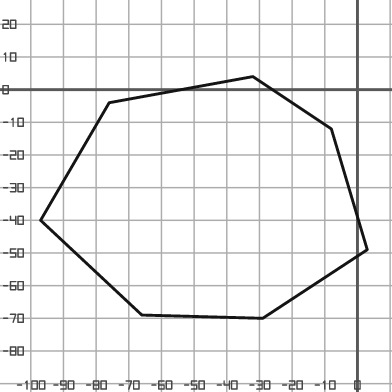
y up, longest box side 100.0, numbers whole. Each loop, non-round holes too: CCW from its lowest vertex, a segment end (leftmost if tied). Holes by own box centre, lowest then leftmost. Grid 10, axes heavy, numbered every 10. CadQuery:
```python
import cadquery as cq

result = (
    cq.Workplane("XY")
    .moveTo(-29.0, -70.0)
    .lineTo(3.0, -49.0)
    .lineTo(-8.0, -12.0)
    .lineTo(-32.0, 4.0)
    .lineTo(-76.0, -4.0)
    .lineTo(-97.0, -40.0)
    .lineTo(-66.0, -69.0)
    .close()
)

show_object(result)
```